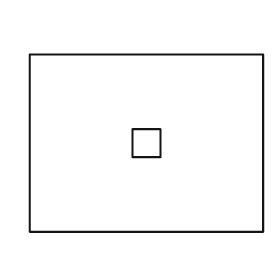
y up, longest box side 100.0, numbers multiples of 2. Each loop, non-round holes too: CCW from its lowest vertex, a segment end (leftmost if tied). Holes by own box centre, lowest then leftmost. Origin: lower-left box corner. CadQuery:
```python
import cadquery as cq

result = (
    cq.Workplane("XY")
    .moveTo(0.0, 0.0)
    .lineTo(100.0, 0.0)
    .lineTo(100.0, 76.0)
    .lineTo(0.0, 76.0)
    .close()
    .moveTo(44.0, 32.0)
    .lineTo(56.0, 32.0)
    .lineTo(56.0, 44.0)
    .lineTo(44.0, 44.0)
    .close()
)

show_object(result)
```